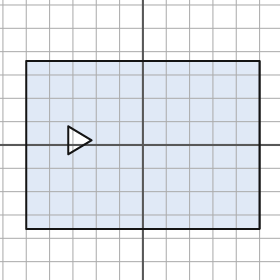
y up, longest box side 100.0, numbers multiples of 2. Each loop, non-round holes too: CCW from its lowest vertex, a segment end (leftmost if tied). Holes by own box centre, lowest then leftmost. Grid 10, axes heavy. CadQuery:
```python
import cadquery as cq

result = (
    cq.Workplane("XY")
    .moveTo(-50.0, -36.0)
    .lineTo(50.0, -36.0)
    .lineTo(50.0, 36.0)
    .lineTo(-50.0, 36.0)
    .close()
    .moveTo(-32.0, -4.0)
    .lineTo(-22.0, 2.0)
    .lineTo(-32.0, 8.0)
    .close()
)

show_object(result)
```